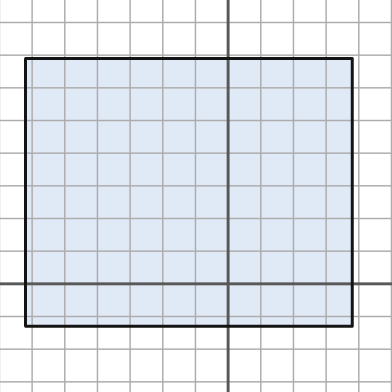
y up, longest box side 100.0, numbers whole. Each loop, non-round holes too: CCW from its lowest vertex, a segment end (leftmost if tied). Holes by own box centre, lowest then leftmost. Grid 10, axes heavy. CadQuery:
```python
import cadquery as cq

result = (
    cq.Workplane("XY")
    .moveTo(-62.0, -13.0)
    .lineTo(38.0, -13.0)
    .lineTo(38.0, 69.0)
    .lineTo(-62.0, 69.0)
    .close()
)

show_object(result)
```